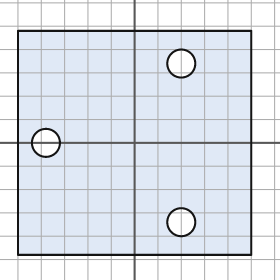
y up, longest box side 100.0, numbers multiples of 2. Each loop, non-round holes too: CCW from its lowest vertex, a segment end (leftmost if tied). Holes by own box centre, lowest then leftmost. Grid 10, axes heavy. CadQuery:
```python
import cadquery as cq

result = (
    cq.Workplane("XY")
    .moveTo(-50.0, -48.0)
    .lineTo(50.0, -48.0)
    .lineTo(50.0, 48.0)
    .lineTo(-50.0, 48.0)
    .close()
    .moveTo(20.0, -34.0)
    .circle(6.0)
    .moveTo(-38.0, 0.0)
    .circle(6.0)
    .moveTo(20.0, 34.0)
    .circle(6.0)
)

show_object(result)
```